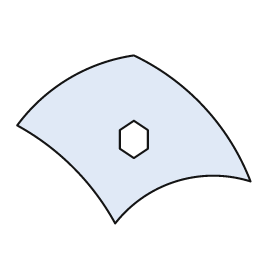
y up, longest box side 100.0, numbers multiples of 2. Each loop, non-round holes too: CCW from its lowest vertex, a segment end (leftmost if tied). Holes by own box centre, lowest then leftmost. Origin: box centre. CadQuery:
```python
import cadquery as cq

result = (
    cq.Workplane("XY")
    .moveTo(-8.0, -36.0)
    .threePointArc((18.0, -18.0), (50.0, -18.0))
    .threePointArc((30.0, 14.0), (0.0, 36.0))
    .threePointArc((-28.0, 26.0), (-50.0, 6.0))
    .threePointArc((-26.0, -12.0), (-8.0, -36.0))
    .close()
    .moveTo(0.0, -8.0)
    .lineTo(6.0, -4.0)
    .lineTo(6.0, 4.0)
    .lineTo(0.0, 8.0)
    .lineTo(-6.0, 4.0)
    .lineTo(-6.0, -4.0)
    .close()
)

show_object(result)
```